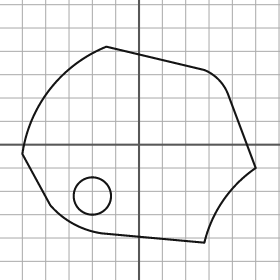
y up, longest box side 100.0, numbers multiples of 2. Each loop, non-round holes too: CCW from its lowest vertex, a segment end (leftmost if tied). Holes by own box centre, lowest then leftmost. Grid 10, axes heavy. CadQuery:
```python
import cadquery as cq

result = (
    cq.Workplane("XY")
    .moveTo(28.0, -42.0)
    .threePointArc((36.0, -24.0), (50.0, -10.0))
    .lineTo(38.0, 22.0)
    .threePointArc((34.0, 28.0), (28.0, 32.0))
    .lineTo(-14.0, 42.0)
    .threePointArc((-38.0, 24.0), (-50.0, -4.0))
    .lineTo(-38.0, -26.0)
    .threePointArc((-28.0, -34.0), (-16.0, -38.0))
    .close()
    .moveTo(-20.0, -22.0)
    .circle(8.0)
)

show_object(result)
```